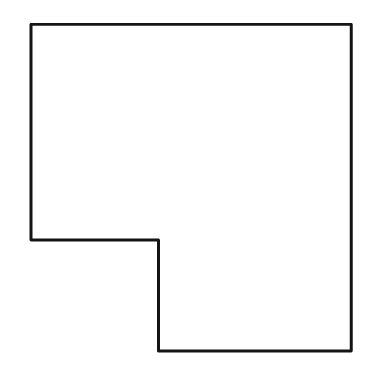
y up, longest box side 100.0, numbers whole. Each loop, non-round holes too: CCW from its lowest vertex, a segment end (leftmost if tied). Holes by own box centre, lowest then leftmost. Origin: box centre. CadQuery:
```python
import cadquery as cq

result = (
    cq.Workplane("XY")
    .moveTo(-10.0, -50.0)
    .lineTo(49.0, -50.0)
    .lineTo(49.0, 50.0)
    .lineTo(-49.0, 50.0)
    .lineTo(-49.0, -16.0)
    .lineTo(-10.0, -16.0)
    .close()
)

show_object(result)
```